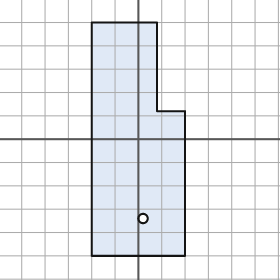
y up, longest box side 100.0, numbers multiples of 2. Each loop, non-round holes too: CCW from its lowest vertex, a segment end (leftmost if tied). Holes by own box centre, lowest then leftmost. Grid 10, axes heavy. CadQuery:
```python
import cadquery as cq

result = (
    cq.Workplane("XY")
    .moveTo(-20.0, -50.0)
    .lineTo(20.0, -50.0)
    .lineTo(20.0, 12.0)
    .lineTo(8.0, 12.0)
    .lineTo(8.0, 50.0)
    .lineTo(-20.0, 50.0)
    .close()
    .moveTo(2.0, -34.0)
    .circle(2.0)
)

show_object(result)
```